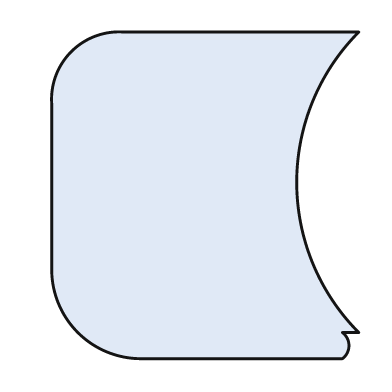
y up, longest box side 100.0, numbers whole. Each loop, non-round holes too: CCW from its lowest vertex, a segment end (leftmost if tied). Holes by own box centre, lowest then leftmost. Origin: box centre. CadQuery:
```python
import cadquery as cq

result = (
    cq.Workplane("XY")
    .moveTo(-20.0, -50.0)
    .lineTo(42.0, -50.0)
    .threePointArc((44.0, -46.0), (42.0, -42.0))
    .lineTo(47.0, -42.0)
    .threePointArc((28.0, 4.0), (47.0, 50.0))
    .lineTo(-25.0, 50.0)
    .threePointArc((-41.0, 44.0), (-47.0, 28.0))
    .lineTo(-47.0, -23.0)
    .threePointArc((-39.0, -42.0), (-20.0, -50.0))
    .close()
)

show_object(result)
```